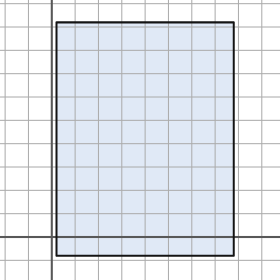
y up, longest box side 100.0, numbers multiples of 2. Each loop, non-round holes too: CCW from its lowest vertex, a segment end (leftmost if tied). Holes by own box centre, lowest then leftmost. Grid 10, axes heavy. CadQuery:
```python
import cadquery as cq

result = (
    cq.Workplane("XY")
    .moveTo(2.0, -8.0)
    .lineTo(78.0, -8.0)
    .lineTo(78.0, 92.0)
    .lineTo(2.0, 92.0)
    .close()
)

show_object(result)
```